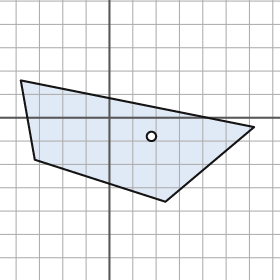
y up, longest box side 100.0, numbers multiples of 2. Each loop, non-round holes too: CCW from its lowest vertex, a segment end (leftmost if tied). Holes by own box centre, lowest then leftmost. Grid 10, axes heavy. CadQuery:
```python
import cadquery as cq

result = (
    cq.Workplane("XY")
    .moveTo(24.0, -36.0)
    .lineTo(62.0, -4.0)
    .lineTo(-38.0, 16.0)
    .lineTo(-32.0, -18.0)
    .close()
    .moveTo(18.0, -8.0)
    .circle(2.0)
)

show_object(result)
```